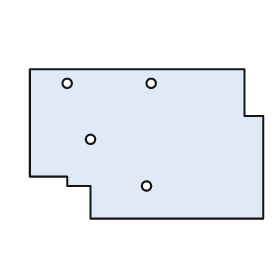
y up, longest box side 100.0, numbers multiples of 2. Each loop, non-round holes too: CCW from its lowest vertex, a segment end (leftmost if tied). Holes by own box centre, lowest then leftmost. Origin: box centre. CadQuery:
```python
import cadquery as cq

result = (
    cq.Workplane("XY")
    .moveTo(-24.0, -32.0)
    .lineTo(50.0, -32.0)
    .lineTo(50.0, 12.0)
    .lineTo(42.0, 12.0)
    .lineTo(42.0, 32.0)
    .lineTo(-50.0, 32.0)
    .lineTo(-50.0, -14.0)
    .lineTo(-34.0, -14.0)
    .lineTo(-34.0, -18.0)
    .lineTo(-24.0, -18.0)
    .close()
    .moveTo(0.0, -18.0)
    .circle(2.0)
    .moveTo(-24.0, 2.0)
    .circle(2.0)
    .moveTo(-34.0, 26.0)
    .circle(2.0)
    .moveTo(2.0, 26.0)
    .circle(2.0)
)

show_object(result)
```